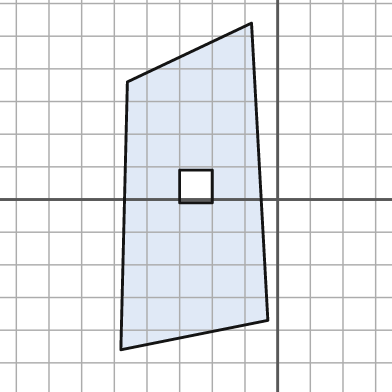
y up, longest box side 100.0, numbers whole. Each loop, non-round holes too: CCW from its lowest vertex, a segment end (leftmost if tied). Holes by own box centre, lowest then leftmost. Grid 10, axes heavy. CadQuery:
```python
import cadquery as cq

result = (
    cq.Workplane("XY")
    .moveTo(-48.0, -46.0)
    .lineTo(-3.0, -37.0)
    .lineTo(-8.0, 54.0)
    .lineTo(-46.0, 36.0)
    .close()
    .moveTo(-30.0, -1.0)
    .lineTo(-20.0, -1.0)
    .lineTo(-20.0, 9.0)
    .lineTo(-30.0, 9.0)
    .close()
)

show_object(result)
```